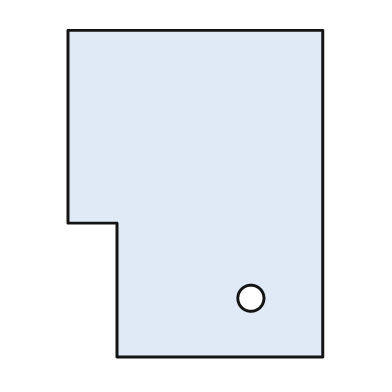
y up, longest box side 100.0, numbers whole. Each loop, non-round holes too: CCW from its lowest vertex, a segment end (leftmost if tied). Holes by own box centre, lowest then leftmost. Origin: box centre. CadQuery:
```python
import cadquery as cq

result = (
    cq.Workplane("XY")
    .moveTo(-24.0, -50.0)
    .lineTo(39.0, -50.0)
    .lineTo(39.0, 50.0)
    .lineTo(-39.0, 50.0)
    .lineTo(-39.0, -9.0)
    .lineTo(-24.0, -9.0)
    .close()
    .moveTo(17.0, -32.0)
    .circle(4.0)
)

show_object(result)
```